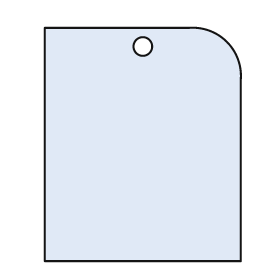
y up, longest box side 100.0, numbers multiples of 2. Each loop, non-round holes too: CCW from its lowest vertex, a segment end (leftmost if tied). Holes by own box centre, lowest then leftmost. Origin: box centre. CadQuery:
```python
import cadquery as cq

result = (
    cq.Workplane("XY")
    .moveTo(-42.0, -50.0)
    .lineTo(42.0, -50.0)
    .lineTo(42.0, 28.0)
    .threePointArc((36.0, 44.0), (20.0, 50.0))
    .lineTo(-42.0, 50.0)
    .close()
    .moveTo(0.0, 42.0)
    .circle(4.0)
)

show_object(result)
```